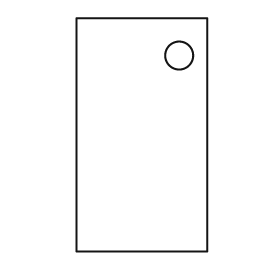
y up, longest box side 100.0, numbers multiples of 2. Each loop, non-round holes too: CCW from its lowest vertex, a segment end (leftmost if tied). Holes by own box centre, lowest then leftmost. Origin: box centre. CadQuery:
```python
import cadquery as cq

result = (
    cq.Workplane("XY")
    .moveTo(-28.0, -50.0)
    .lineTo(28.0, -50.0)
    .lineTo(28.0, 50.0)
    .lineTo(-28.0, 50.0)
    .close()
    .moveTo(16.0, 34.0)
    .circle(6.0)
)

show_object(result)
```